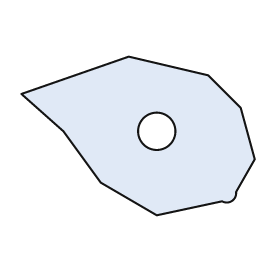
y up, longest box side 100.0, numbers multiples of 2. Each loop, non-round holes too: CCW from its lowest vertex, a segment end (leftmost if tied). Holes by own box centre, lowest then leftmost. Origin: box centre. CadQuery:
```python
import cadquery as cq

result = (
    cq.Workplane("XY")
    .moveTo(8.0, -34.0)
    .lineTo(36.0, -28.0)
    .threePointArc((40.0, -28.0), (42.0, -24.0))
    .lineTo(50.0, -10.0)
    .lineTo(44.0, 12.0)
    .lineTo(30.0, 26.0)
    .lineTo(-4.0, 34.0)
    .lineTo(-50.0, 18.0)
    .lineTo(-32.0, 2.0)
    .lineTo(-16.0, -20.0)
    .close()
    .moveTo(8.0, 2.0)
    .circle(8.0)
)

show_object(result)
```